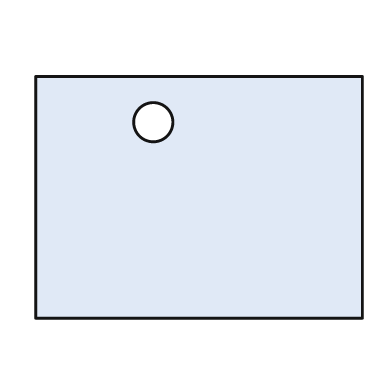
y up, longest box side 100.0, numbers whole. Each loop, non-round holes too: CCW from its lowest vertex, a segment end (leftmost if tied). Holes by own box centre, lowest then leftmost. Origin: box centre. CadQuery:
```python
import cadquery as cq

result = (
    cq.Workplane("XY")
    .moveTo(-50.0, -37.0)
    .lineTo(50.0, -37.0)
    .lineTo(50.0, 37.0)
    .lineTo(-50.0, 37.0)
    .close()
    .moveTo(-14.0, 23.0)
    .circle(6.0)
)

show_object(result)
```